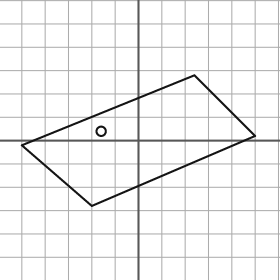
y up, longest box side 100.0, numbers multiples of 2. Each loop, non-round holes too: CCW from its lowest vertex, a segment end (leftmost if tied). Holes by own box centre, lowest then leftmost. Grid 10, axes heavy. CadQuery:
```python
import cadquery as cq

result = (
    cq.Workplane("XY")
    .moveTo(-20.0, -28.0)
    .lineTo(50.0, 2.0)
    .lineTo(24.0, 28.0)
    .lineTo(-50.0, -2.0)
    .close()
    .moveTo(-16.0, 4.0)
    .circle(2.0)
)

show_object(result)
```